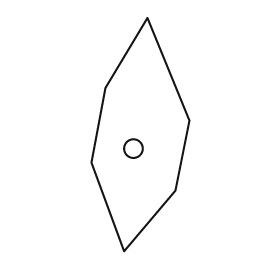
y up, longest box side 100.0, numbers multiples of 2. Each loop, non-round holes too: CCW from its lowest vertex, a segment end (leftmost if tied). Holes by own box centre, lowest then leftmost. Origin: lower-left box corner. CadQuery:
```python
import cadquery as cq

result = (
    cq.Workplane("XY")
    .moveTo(14.0, 0.0)
    .lineTo(36.0, 26.0)
    .lineTo(42.0, 56.0)
    .lineTo(24.0, 100.0)
    .lineTo(6.0, 70.0)
    .lineTo(0.0, 38.0)
    .close()
    .moveTo(18.0, 44.0)
    .circle(4.0)
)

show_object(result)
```